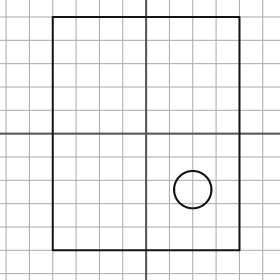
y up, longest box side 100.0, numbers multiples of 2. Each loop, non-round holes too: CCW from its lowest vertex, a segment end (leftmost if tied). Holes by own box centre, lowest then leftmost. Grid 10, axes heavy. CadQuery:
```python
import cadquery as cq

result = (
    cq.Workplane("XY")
    .moveTo(-40.0, -50.0)
    .lineTo(40.0, -50.0)
    .lineTo(40.0, 50.0)
    .lineTo(-40.0, 50.0)
    .close()
    .moveTo(20.0, -24.0)
    .circle(8.0)
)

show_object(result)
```